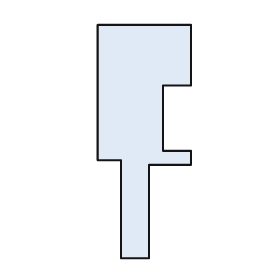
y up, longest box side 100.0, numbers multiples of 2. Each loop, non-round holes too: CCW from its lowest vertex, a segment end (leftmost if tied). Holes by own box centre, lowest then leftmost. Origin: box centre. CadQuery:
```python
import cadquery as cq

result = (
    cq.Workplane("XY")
    .moveTo(-10.0, -50.0)
    .lineTo(2.0, -50.0)
    .lineTo(2.0, -10.0)
    .lineTo(20.0, -10.0)
    .lineTo(20.0, -4.0)
    .lineTo(8.0, -4.0)
    .lineTo(8.0, 24.0)
    .lineTo(20.0, 24.0)
    .lineTo(20.0, 50.0)
    .lineTo(-20.0, 50.0)
    .lineTo(-20.0, -8.0)
    .lineTo(-10.0, -8.0)
    .close()
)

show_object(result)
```